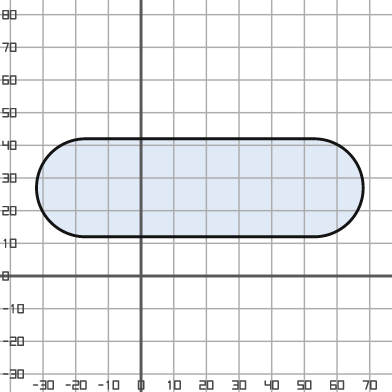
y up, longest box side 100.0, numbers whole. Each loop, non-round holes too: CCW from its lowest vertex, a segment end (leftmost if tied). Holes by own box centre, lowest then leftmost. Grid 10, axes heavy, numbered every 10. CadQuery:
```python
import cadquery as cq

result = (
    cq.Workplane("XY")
    .moveTo(-17.0, 12.0)
    .lineTo(53.0, 12.0)
    .threePointArc((68.0, 27.0), (53.0, 42.0))
    .lineTo(-17.0, 42.0)
    .threePointArc((-32.0, 27.0), (-17.0, 12.0))
    .close()
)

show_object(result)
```